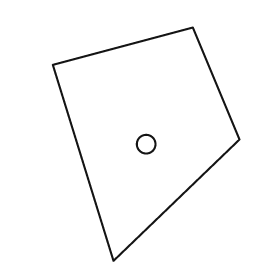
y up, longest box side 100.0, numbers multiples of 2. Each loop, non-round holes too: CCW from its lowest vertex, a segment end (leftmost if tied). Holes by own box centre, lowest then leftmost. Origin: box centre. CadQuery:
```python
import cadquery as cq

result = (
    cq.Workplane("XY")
    .moveTo(-14.0, -50.0)
    .lineTo(40.0, 2.0)
    .lineTo(20.0, 50.0)
    .lineTo(-40.0, 34.0)
    .close()
    .moveTo(0.0, 0.0)
    .circle(4.0)
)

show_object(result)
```